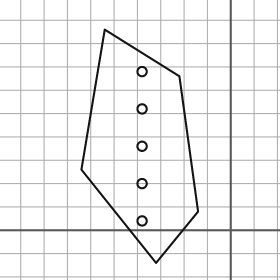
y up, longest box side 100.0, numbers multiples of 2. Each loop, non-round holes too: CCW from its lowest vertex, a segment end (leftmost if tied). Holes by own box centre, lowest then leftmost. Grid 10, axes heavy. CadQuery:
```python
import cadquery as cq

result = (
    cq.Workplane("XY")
    .moveTo(-32.0, -14.0)
    .lineTo(-14.0, 8.0)
    .lineTo(-22.0, 66.0)
    .lineTo(-54.0, 86.0)
    .lineTo(-64.0, 26.0)
    .close()
    .moveTo(-38.0, 4.0)
    .circle(2.0)
    .moveTo(-38.0, 20.0)
    .circle(2.0)
    .moveTo(-38.0, 36.0)
    .circle(2.0)
    .moveTo(-38.0, 52.0)
    .circle(2.0)
    .moveTo(-38.0, 68.0)
    .circle(2.0)
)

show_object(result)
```